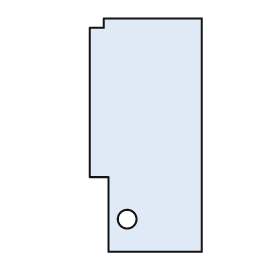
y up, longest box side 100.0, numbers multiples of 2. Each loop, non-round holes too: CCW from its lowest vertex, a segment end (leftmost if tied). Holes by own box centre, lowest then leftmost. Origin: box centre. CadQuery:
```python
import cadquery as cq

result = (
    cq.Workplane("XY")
    .moveTo(-16.0, -50.0)
    .lineTo(24.0, -50.0)
    .lineTo(24.0, 50.0)
    .lineTo(-18.0, 50.0)
    .lineTo(-18.0, 46.0)
    .lineTo(-24.0, 46.0)
    .lineTo(-24.0, -18.0)
    .lineTo(-16.0, -18.0)
    .close()
    .moveTo(-8.0, -36.0)
    .circle(4.0)
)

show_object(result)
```